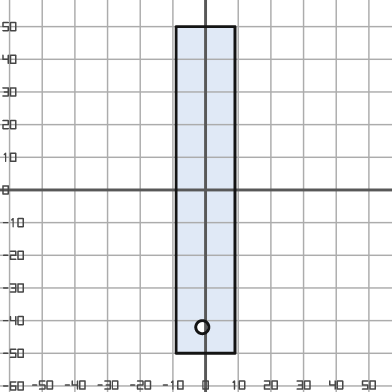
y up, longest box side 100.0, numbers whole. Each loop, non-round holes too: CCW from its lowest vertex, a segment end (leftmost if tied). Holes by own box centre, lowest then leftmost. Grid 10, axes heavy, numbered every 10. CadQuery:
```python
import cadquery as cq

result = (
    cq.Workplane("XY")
    .moveTo(-9.0, -50.0)
    .lineTo(9.0, -50.0)
    .lineTo(9.0, 50.0)
    .lineTo(-9.0, 50.0)
    .close()
    .moveTo(-1.0, -42.0)
    .circle(2.0)
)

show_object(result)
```